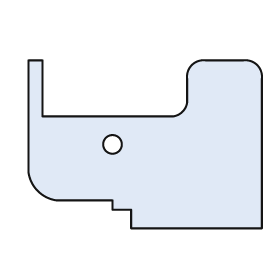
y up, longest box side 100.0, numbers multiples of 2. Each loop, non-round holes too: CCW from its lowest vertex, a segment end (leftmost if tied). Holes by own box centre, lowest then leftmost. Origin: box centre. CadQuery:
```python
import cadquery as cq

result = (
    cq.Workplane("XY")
    .moveTo(-6.0, -36.0)
    .lineTo(50.0, -36.0)
    .lineTo(50.0, 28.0)
    .threePointArc((48.0, 34.0), (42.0, 36.0))
    .lineTo(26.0, 36.0)
    .threePointArc((20.0, 34.0), (18.0, 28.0))
    .lineTo(18.0, 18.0)
    .threePointArc((16.0, 14.0), (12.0, 12.0))
    .lineTo(-44.0, 12.0)
    .lineTo(-44.0, 36.0)
    .lineTo(-50.0, 36.0)
    .lineTo(-50.0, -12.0)
    .threePointArc((-46.0, -20.0), (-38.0, -24.0))
    .lineTo(-14.0, -24.0)
    .lineTo(-14.0, -28.0)
    .lineTo(-6.0, -28.0)
    .close()
    .moveTo(-14.0, 0.0)
    .circle(4.0)
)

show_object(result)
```